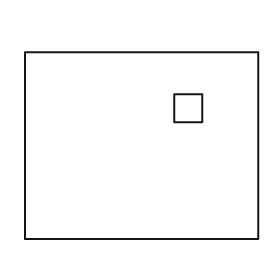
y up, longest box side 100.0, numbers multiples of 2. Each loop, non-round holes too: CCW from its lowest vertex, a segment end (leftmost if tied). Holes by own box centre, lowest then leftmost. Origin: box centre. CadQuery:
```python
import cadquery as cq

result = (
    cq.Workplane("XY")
    .moveTo(-50.0, -40.0)
    .lineTo(50.0, -40.0)
    .lineTo(50.0, 40.0)
    .lineTo(-50.0, 40.0)
    .close()
    .moveTo(14.0, 10.0)
    .lineTo(26.0, 10.0)
    .lineTo(26.0, 22.0)
    .lineTo(14.0, 22.0)
    .close()
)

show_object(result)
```